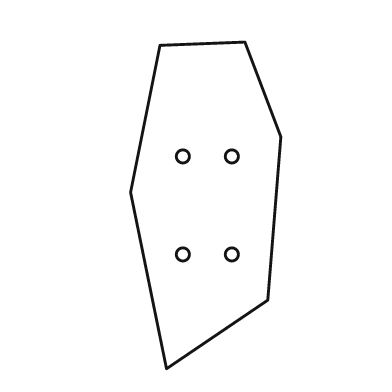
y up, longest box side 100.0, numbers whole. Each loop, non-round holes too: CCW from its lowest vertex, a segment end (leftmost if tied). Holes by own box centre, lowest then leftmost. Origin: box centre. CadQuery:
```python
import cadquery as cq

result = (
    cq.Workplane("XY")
    .moveTo(-12.0, -50.0)
    .lineTo(19.0, -29.0)
    .lineTo(23.0, 21.0)
    .lineTo(12.0, 50.0)
    .lineTo(-14.0, 49.0)
    .lineTo(-23.0, 4.0)
    .close()
    .moveTo(-7.0, -15.0)
    .circle(2.0)
    .moveTo(8.0, -15.0)
    .circle(2.0)
    .moveTo(-7.0, 15.0)
    .circle(2.0)
    .moveTo(8.0, 15.0)
    .circle(2.0)
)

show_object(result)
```